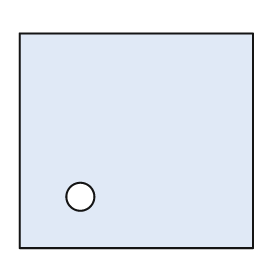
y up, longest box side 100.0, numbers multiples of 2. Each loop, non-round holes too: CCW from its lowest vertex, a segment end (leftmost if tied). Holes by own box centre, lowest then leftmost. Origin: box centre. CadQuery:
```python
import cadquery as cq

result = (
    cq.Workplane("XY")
    .moveTo(-50.0, -46.0)
    .lineTo(50.0, -46.0)
    .lineTo(50.0, 46.0)
    .lineTo(-50.0, 46.0)
    .close()
    .moveTo(-24.0, -24.0)
    .circle(6.0)
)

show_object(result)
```